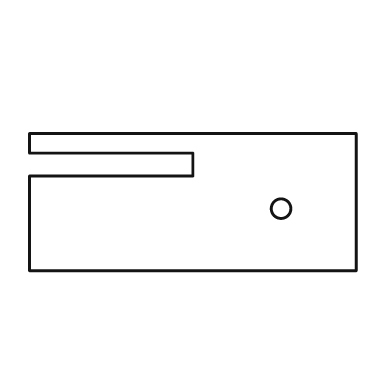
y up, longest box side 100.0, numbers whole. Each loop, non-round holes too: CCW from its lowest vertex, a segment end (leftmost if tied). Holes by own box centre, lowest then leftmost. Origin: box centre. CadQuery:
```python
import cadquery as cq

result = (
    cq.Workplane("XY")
    .moveTo(-50.0, -21.0)
    .lineTo(50.0, -21.0)
    .lineTo(50.0, 21.0)
    .lineTo(-50.0, 21.0)
    .lineTo(-50.0, 15.0)
    .lineTo(0.0, 15.0)
    .lineTo(0.0, 8.0)
    .lineTo(-50.0, 8.0)
    .close()
    .moveTo(27.0, -2.0)
    .circle(3.0)
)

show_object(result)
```